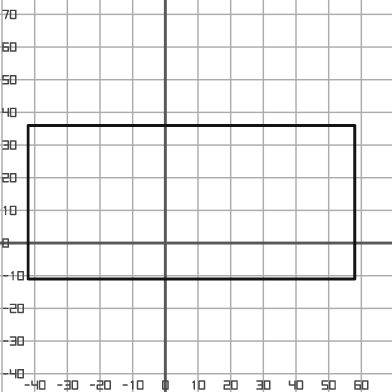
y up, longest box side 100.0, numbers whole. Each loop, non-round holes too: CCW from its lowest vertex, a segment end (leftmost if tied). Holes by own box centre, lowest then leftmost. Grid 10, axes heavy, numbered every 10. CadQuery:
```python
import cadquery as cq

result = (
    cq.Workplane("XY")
    .moveTo(-42.0, -11.0)
    .lineTo(58.0, -11.0)
    .lineTo(58.0, 36.0)
    .lineTo(-42.0, 36.0)
    .close()
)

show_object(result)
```